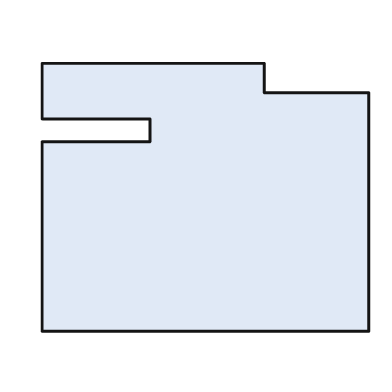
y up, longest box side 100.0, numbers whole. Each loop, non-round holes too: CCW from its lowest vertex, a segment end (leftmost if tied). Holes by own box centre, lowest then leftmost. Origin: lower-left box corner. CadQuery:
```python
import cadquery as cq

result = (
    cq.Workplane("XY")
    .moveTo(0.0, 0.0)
    .lineTo(100.0, 0.0)
    .lineTo(100.0, 73.0)
    .lineTo(68.0, 73.0)
    .lineTo(68.0, 82.0)
    .lineTo(0.0, 82.0)
    .lineTo(0.0, 65.0)
    .lineTo(33.0, 65.0)
    .lineTo(33.0, 58.0)
    .lineTo(0.0, 58.0)
    .close()
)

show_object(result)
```